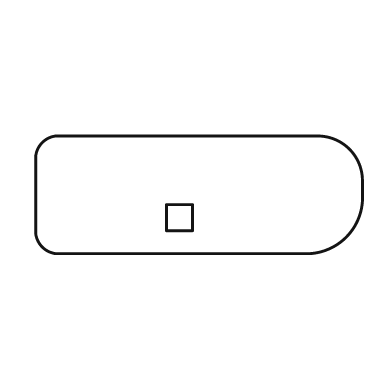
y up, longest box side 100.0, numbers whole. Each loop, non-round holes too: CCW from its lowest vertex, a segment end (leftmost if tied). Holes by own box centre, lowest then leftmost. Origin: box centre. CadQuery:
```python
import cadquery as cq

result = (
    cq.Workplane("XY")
    .moveTo(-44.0, -18.0)
    .lineTo(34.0, -18.0)
    .threePointArc((45.0, -13.0), (50.0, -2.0))
    .lineTo(50.0, 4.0)
    .threePointArc((46.0, 14.0), (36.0, 18.0))
    .lineTo(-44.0, 18.0)
    .threePointArc((-48.0, 16.0), (-50.0, 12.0))
    .lineTo(-50.0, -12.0)
    .threePointArc((-48.0, -16.0), (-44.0, -18.0))
    .close()
    .moveTo(-10.0, -11.0)
    .lineTo(-2.0, -11.0)
    .lineTo(-2.0, -3.0)
    .lineTo(-10.0, -3.0)
    .close()
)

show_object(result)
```